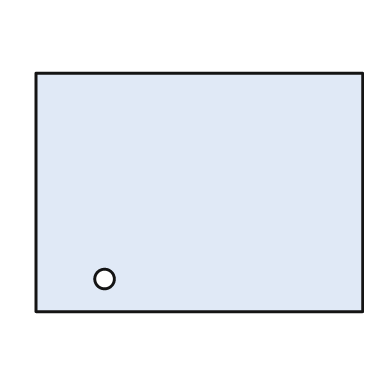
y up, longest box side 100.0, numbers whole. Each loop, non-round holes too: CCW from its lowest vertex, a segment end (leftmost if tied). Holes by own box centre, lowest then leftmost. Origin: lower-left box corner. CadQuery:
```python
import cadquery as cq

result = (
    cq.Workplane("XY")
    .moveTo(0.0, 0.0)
    .lineTo(100.0, 0.0)
    .lineTo(100.0, 73.0)
    .lineTo(0.0, 73.0)
    .close()
    .moveTo(21.0, 10.0)
    .circle(3.0)
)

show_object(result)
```